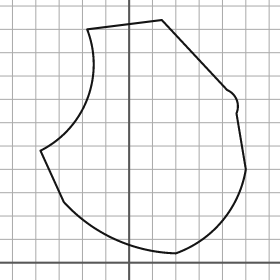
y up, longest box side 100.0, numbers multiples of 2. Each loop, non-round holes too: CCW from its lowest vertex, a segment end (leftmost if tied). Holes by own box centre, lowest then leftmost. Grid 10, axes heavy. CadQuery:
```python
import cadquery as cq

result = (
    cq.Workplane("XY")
    .moveTo(20.0, 4.0)
    .threePointArc((40.0, 18.0), (50.0, 40.0))
    .lineTo(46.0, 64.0)
    .threePointArc((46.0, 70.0), (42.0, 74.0))
    .lineTo(14.0, 104.0)
    .lineTo(-18.0, 100.0)
    .threePointArc((-18.0, 70.0), (-38.0, 48.0))
    .lineTo(-28.0, 26.0)
    .threePointArc((-6.0, 10.0), (20.0, 4.0))
    .close()
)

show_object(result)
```